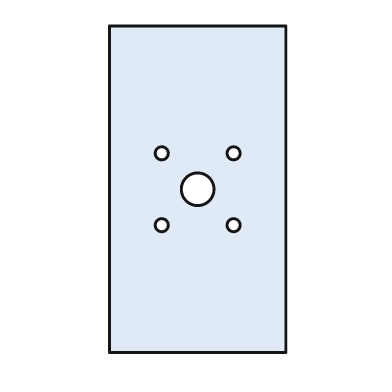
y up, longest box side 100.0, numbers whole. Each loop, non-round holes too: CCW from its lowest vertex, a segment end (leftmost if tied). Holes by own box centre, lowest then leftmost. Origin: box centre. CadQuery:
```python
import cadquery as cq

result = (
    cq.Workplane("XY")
    .moveTo(-27.0, -50.0)
    .lineTo(27.0, -50.0)
    .lineTo(27.0, 50.0)
    .lineTo(-27.0, 50.0)
    .close()
    .moveTo(-11.0, -11.0)
    .circle(2.0)
    .moveTo(11.0, -11.0)
    .circle(2.0)
    .moveTo(0.0, 0.0)
    .circle(5.0)
    .moveTo(-11.0, 11.0)
    .circle(2.0)
    .moveTo(11.0, 11.0)
    .circle(2.0)
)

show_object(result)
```